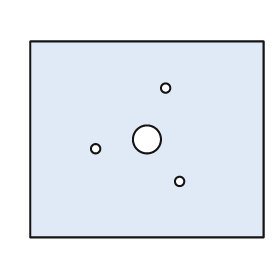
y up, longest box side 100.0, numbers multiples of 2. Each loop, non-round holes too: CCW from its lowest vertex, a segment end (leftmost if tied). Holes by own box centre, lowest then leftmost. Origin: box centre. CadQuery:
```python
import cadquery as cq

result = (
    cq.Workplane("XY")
    .moveTo(-50.0, -42.0)
    .lineTo(50.0, -42.0)
    .lineTo(50.0, 42.0)
    .lineTo(-50.0, 42.0)
    .close()
    .moveTo(14.0, -18.0)
    .circle(2.0)
    .moveTo(-22.0, -4.0)
    .circle(2.0)
    .moveTo(0.0, 0.0)
    .circle(6.0)
    .moveTo(8.0, 22.0)
    .circle(2.0)
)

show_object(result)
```